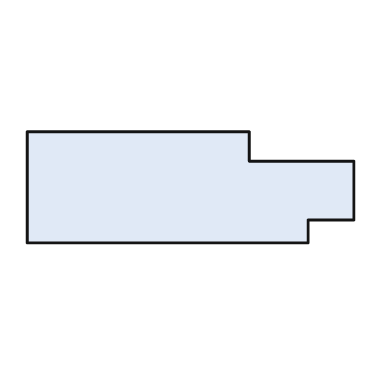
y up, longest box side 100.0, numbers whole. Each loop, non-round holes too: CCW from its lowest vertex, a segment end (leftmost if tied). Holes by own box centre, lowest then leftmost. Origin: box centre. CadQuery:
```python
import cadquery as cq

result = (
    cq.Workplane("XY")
    .moveTo(-50.0, -17.0)
    .lineTo(36.0, -17.0)
    .lineTo(36.0, -10.0)
    .lineTo(50.0, -10.0)
    .lineTo(50.0, 8.0)
    .lineTo(18.0, 8.0)
    .lineTo(18.0, 17.0)
    .lineTo(-50.0, 17.0)
    .close()
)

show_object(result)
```